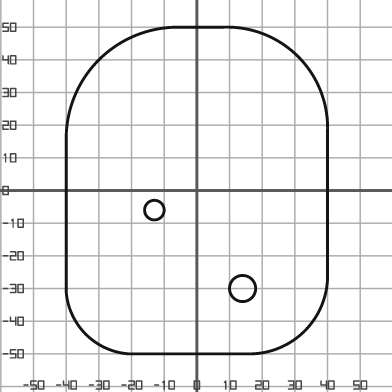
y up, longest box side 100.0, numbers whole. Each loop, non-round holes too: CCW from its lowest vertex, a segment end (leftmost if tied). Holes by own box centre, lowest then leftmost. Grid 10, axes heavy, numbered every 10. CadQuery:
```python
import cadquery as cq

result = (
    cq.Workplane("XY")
    .moveTo(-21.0, -50.0)
    .lineTo(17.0, -50.0)
    .threePointArc((33.0, -43.0), (40.0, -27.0))
    .lineTo(40.0, 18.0)
    .threePointArc((31.0, 41.0), (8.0, 50.0))
    .lineTo(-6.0, 50.0)
    .threePointArc((-30.0, 40.0), (-40.0, 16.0))
    .lineTo(-40.0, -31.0)
    .threePointArc((-34.0, -44.0), (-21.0, -50.0))
    .close()
    .moveTo(14.0, -30.0)
    .circle(4.0)
    .moveTo(-13.0, -6.0)
    .circle(3.0)
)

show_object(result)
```